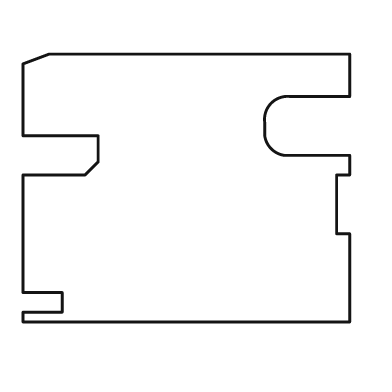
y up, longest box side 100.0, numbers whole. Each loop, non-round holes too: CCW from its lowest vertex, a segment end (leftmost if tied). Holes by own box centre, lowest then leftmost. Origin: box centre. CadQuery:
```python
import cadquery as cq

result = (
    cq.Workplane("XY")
    .moveTo(-50.0, -41.0)
    .lineTo(50.0, -41.0)
    .lineTo(50.0, -14.0)
    .lineTo(46.0, -14.0)
    .lineTo(46.0, 4.0)
    .lineTo(50.0, 4.0)
    .lineTo(50.0, 10.0)
    .lineTo(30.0, 10.0)
    .threePointArc((26.0, 12.0), (24.0, 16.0))
    .lineTo(24.0, 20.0)
    .threePointArc((26.0, 26.0), (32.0, 28.0))
    .lineTo(50.0, 28.0)
    .lineTo(50.0, 41.0)
    .lineTo(-42.0, 41.0)
    .lineTo(-50.0, 38.0)
    .lineTo(-50.0, 16.0)
    .lineTo(-27.0, 16.0)
    .lineTo(-27.0, 8.0)
    .lineTo(-31.0, 4.0)
    .lineTo(-50.0, 4.0)
    .lineTo(-50.0, -32.0)
    .lineTo(-38.0, -32.0)
    .lineTo(-38.0, -38.0)
    .lineTo(-50.0, -38.0)
    .close()
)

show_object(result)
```